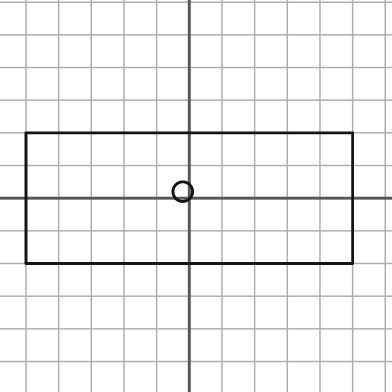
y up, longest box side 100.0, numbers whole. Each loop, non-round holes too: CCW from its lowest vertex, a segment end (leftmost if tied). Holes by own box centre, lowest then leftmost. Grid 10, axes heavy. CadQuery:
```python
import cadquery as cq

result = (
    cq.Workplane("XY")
    .moveTo(-50.0, -20.0)
    .lineTo(50.0, -20.0)
    .lineTo(50.0, 20.0)
    .lineTo(-50.0, 20.0)
    .close()
    .moveTo(-2.0, 2.0)
    .circle(3.0)
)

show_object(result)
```